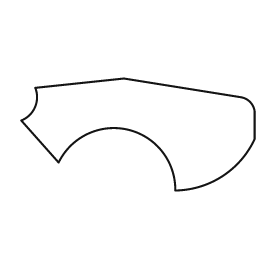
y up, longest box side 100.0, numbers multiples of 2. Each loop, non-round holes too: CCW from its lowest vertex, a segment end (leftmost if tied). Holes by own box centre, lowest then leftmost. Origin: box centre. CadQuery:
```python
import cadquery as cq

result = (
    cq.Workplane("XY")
    .moveTo(16.0, -24.0)
    .threePointArc((36.0, -18.0), (50.0, -2.0))
    .lineTo(50.0, 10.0)
    .threePointArc((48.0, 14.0), (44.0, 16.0))
    .lineTo(-6.0, 24.0)
    .lineTo(-44.0, 20.0)
    .threePointArc((-44.0, 12.0), (-50.0, 6.0))
    .lineTo(-34.0, -12.0)
    .threePointArc((-4.0, 2.0), (16.0, -24.0))
    .close()
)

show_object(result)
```